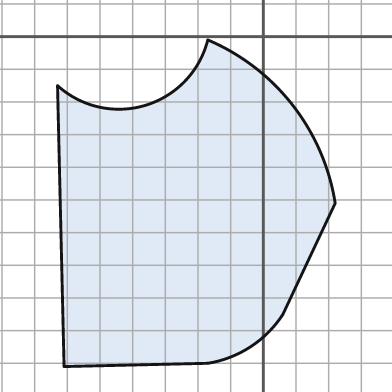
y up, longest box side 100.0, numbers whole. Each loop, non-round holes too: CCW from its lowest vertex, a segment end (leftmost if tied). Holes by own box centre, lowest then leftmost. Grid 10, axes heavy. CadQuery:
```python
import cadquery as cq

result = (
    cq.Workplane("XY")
    .moveTo(-61.0, -101.0)
    .lineTo(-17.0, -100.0)
    .threePointArc((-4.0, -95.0), (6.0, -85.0))
    .lineTo(22.0, -51.0)
    .threePointArc((9.0, -21.0), (-17.0, -1.0))
    .threePointArc((-36.0, -21.0), (-63.0, -15.0))
    .close()
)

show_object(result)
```